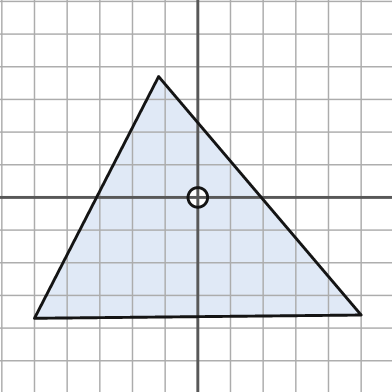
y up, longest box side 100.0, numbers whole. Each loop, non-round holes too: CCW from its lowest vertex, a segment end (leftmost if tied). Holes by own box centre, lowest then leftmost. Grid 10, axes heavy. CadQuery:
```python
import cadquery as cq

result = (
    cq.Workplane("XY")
    .moveTo(-50.0, -37.0)
    .lineTo(50.0, -36.0)
    .lineTo(-12.0, 37.0)
    .close()
    .moveTo(0.0, 0.0)
    .circle(3.0)
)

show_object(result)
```